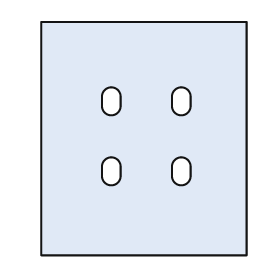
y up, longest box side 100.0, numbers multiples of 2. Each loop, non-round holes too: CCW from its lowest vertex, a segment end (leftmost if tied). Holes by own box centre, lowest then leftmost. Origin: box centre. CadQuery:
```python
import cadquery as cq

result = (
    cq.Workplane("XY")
    .moveTo(-44.0, -50.0)
    .lineTo(44.0, -50.0)
    .lineTo(44.0, 50.0)
    .lineTo(-44.0, 50.0)
    .close()
    .moveTo(-18.0, -16.0)
    .threePointArc((-14.0, -20.0), (-10.0, -16.0))
    .lineTo(-10.0, -12.0)
    .threePointArc((-14.0, -8.0), (-18.0, -12.0))
    .close()
    .moveTo(12.0, -16.0)
    .threePointArc((16.0, -20.0), (20.0, -16.0))
    .lineTo(20.0, -12.0)
    .threePointArc((16.0, -8.0), (12.0, -12.0))
    .close()
    .moveTo(-18.0, 14.0)
    .threePointArc((-14.0, 10.0), (-10.0, 14.0))
    .lineTo(-10.0, 18.0)
    .threePointArc((-14.0, 22.0), (-18.0, 18.0))
    .close()
    .moveTo(12.0, 14.0)
    .threePointArc((16.0, 10.0), (20.0, 14.0))
    .lineTo(20.0, 18.0)
    .threePointArc((16.0, 22.0), (12.0, 18.0))
    .close()
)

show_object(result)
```